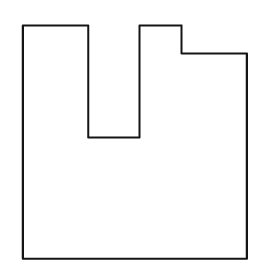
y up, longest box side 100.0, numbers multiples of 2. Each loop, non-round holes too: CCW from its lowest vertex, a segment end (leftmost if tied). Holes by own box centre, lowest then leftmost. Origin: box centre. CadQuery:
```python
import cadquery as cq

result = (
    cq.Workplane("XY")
    .moveTo(-48.0, -50.0)
    .lineTo(48.0, -50.0)
    .lineTo(48.0, 38.0)
    .lineTo(20.0, 38.0)
    .lineTo(20.0, 50.0)
    .lineTo(2.0, 50.0)
    .lineTo(2.0, 2.0)
    .lineTo(-20.0, 2.0)
    .lineTo(-20.0, 50.0)
    .lineTo(-48.0, 50.0)
    .close()
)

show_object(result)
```